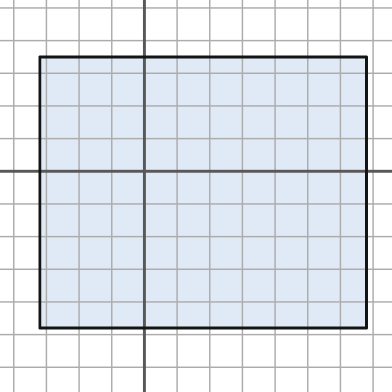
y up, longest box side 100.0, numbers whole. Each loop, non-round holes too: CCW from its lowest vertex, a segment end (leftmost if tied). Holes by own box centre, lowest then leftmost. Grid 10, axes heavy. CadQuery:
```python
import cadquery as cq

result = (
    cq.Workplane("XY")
    .moveTo(-32.0, -48.0)
    .lineTo(68.0, -48.0)
    .lineTo(68.0, 35.0)
    .lineTo(-32.0, 35.0)
    .close()
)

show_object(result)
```